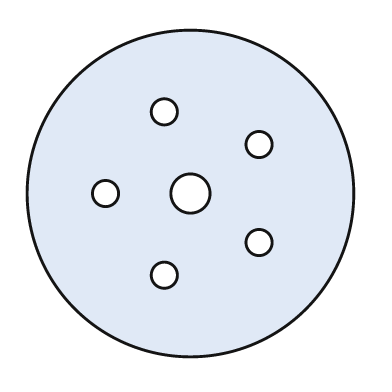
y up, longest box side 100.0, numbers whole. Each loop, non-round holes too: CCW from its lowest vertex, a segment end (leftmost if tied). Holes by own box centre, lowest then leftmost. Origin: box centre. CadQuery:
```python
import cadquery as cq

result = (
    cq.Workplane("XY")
    .moveTo(0.0, 0.0)
    .circle(50.0)
    .moveTo(-8.0, -25.0)
    .circle(4.0)
    .moveTo(21.0, -15.0)
    .circle(4.0)
    .moveTo(-26.0, 0.0)
    .circle(4.0)
    .moveTo(0.0, 0.0)
    .circle(6.0)
    .moveTo(21.0, 15.0)
    .circle(4.0)
    .moveTo(-8.0, 25.0)
    .circle(4.0)
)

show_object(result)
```